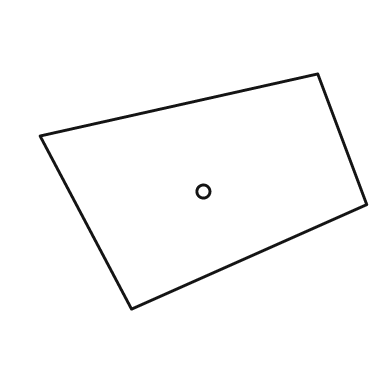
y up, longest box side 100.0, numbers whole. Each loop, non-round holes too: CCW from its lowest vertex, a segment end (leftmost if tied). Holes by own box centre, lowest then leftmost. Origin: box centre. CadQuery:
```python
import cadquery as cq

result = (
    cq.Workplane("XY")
    .moveTo(-22.0, -36.0)
    .lineTo(50.0, -4.0)
    .lineTo(35.0, 36.0)
    .lineTo(-50.0, 17.0)
    .close()
    .moveTo(0.0, 0.0)
    .circle(2.0)
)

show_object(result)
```